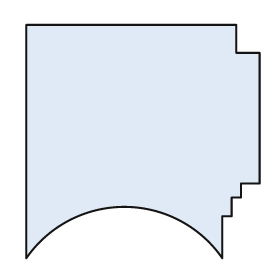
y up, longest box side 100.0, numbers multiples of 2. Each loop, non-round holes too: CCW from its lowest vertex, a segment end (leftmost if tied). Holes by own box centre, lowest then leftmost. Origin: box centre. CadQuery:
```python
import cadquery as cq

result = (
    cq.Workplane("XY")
    .moveTo(-50.0, -50.0)
    .threePointArc((-8.0, -28.0), (34.0, -50.0))
    .lineTo(34.0, -32.0)
    .lineTo(38.0, -32.0)
    .lineTo(38.0, -24.0)
    .lineTo(42.0, -24.0)
    .lineTo(42.0, -18.0)
    .lineTo(50.0, -18.0)
    .lineTo(50.0, 38.0)
    .lineTo(40.0, 38.0)
    .lineTo(40.0, 50.0)
    .lineTo(-50.0, 50.0)
    .close()
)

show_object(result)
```